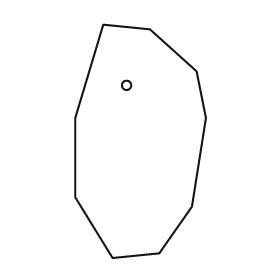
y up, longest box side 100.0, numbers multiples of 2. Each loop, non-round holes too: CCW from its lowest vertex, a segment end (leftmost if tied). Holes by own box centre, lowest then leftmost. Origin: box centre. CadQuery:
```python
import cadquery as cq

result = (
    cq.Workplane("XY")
    .moveTo(-12.0, -50.0)
    .lineTo(8.0, -48.0)
    .lineTo(22.0, -28.0)
    .lineTo(28.0, 10.0)
    .lineTo(24.0, 30.0)
    .lineTo(4.0, 48.0)
    .lineTo(-16.0, 50.0)
    .lineTo(-28.0, 10.0)
    .lineTo(-28.0, -24.0)
    .close()
    .moveTo(-6.0, 24.0)
    .circle(2.0)
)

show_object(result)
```